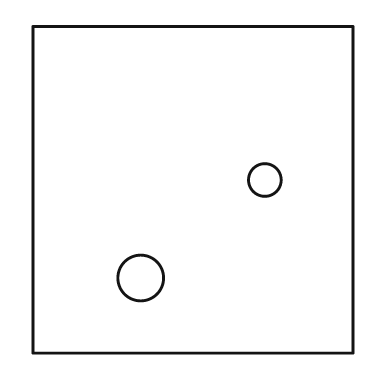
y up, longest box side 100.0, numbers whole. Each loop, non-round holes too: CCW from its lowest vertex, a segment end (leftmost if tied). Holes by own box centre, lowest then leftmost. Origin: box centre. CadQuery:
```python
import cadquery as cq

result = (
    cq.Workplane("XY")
    .moveTo(-49.0, -50.0)
    .lineTo(49.0, -50.0)
    .lineTo(49.0, 50.0)
    .lineTo(-49.0, 50.0)
    .close()
    .moveTo(-16.0, -27.0)
    .circle(7.0)
    .moveTo(22.0, 3.0)
    .circle(5.0)
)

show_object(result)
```